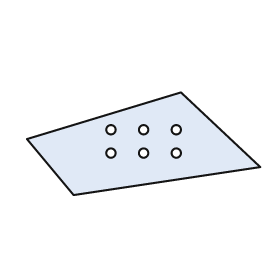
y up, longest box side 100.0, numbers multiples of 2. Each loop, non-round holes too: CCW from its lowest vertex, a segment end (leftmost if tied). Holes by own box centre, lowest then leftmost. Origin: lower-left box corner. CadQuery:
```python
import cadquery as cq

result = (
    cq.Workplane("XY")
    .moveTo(20.0, 0.0)
    .lineTo(100.0, 12.0)
    .lineTo(66.0, 44.0)
    .lineTo(0.0, 24.0)
    .close()
    .moveTo(36.0, 18.0)
    .circle(2.0)
    .moveTo(50.0, 18.0)
    .circle(2.0)
    .moveTo(64.0, 18.0)
    .circle(2.0)
    .moveTo(36.0, 28.0)
    .circle(2.0)
    .moveTo(50.0, 28.0)
    .circle(2.0)
    .moveTo(64.0, 28.0)
    .circle(2.0)
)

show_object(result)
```